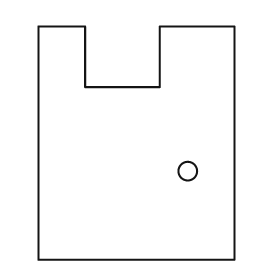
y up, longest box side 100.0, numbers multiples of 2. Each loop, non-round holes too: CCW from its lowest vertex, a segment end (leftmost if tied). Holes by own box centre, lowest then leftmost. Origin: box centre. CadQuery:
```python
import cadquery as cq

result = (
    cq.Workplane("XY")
    .moveTo(-42.0, -50.0)
    .lineTo(42.0, -50.0)
    .lineTo(42.0, 50.0)
    .lineTo(10.0, 50.0)
    .lineTo(10.0, 24.0)
    .lineTo(-22.0, 24.0)
    .lineTo(-22.0, 50.0)
    .lineTo(-42.0, 50.0)
    .close()
    .moveTo(22.0, -12.0)
    .circle(4.0)
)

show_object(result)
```